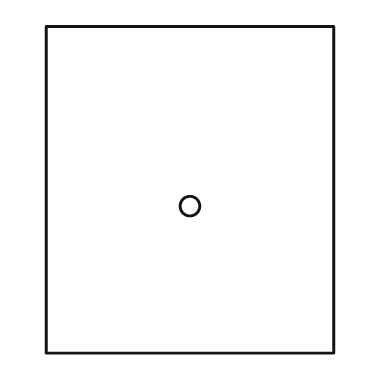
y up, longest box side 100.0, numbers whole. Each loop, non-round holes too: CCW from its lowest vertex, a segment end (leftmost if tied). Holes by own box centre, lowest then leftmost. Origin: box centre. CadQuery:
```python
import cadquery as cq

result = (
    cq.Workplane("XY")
    .moveTo(-44.0, -50.0)
    .lineTo(44.0, -50.0)
    .lineTo(44.0, 50.0)
    .lineTo(-44.0, 50.0)
    .close()
    .moveTo(0.0, -5.0)
    .circle(3.0)
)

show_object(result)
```